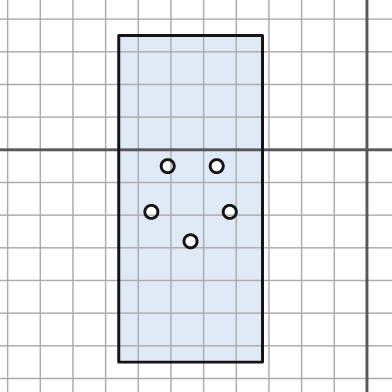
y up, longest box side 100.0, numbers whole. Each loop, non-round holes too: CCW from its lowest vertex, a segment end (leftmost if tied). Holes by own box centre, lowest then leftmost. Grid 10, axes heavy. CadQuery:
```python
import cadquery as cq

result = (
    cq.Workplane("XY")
    .moveTo(-76.0, -65.0)
    .lineTo(-32.0, -65.0)
    .lineTo(-32.0, 35.0)
    .lineTo(-76.0, 35.0)
    .close()
    .moveTo(-54.0, -28.0)
    .circle(2.0)
    .moveTo(-66.0, -19.0)
    .circle(2.0)
    .moveTo(-42.0, -19.0)
    .circle(2.0)
    .moveTo(-61.0, -5.0)
    .circle(2.0)
    .moveTo(-46.0, -5.0)
    .circle(2.0)
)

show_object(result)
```